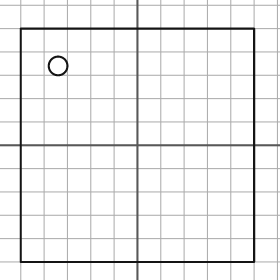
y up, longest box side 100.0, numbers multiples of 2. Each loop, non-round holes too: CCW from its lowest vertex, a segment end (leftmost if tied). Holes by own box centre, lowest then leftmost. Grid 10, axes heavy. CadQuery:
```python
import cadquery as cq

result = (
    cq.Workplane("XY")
    .moveTo(-50.0, -50.0)
    .lineTo(50.0, -50.0)
    .lineTo(50.0, 50.0)
    .lineTo(-50.0, 50.0)
    .close()
    .moveTo(-34.0, 34.0)
    .circle(4.0)
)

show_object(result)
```